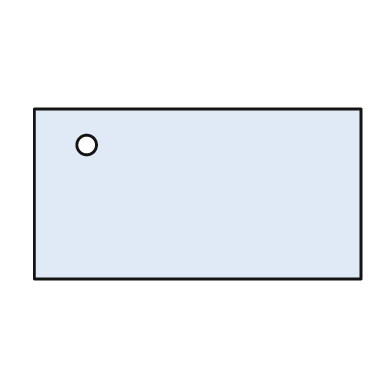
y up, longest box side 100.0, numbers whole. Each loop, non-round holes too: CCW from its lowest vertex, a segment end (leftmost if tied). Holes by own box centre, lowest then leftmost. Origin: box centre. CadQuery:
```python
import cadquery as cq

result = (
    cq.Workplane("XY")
    .moveTo(-50.0, -26.0)
    .lineTo(50.0, -26.0)
    .lineTo(50.0, 26.0)
    .lineTo(-50.0, 26.0)
    .close()
    .moveTo(-34.0, 15.0)
    .circle(3.0)
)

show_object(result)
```